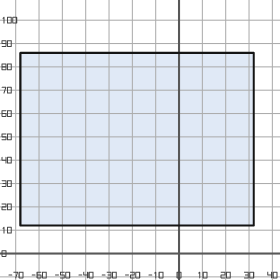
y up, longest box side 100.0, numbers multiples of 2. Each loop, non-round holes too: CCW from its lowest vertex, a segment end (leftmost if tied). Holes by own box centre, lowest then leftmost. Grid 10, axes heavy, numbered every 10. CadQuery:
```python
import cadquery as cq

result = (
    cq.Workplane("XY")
    .moveTo(-68.0, 12.0)
    .lineTo(32.0, 12.0)
    .lineTo(32.0, 86.0)
    .lineTo(-68.0, 86.0)
    .close()
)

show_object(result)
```